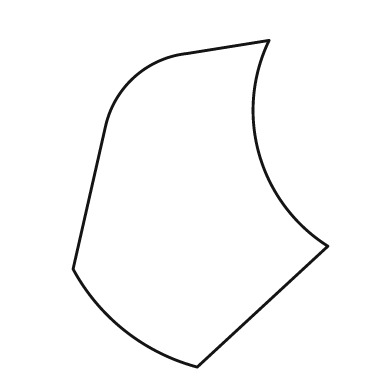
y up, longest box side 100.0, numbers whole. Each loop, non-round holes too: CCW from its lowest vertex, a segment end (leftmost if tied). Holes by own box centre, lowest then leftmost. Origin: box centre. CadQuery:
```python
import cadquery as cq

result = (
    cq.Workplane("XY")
    .moveTo(-1.0, -50.0)
    .lineTo(39.0, -13.0)
    .threePointArc((18.0, 15.0), (21.0, 50.0))
    .lineTo(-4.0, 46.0)
    .threePointArc((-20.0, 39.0), (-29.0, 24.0))
    .lineTo(-39.0, -20.0)
    .threePointArc((-23.0, -39.0), (-1.0, -50.0))
    .close()
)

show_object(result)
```